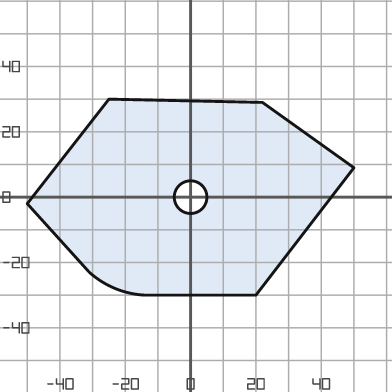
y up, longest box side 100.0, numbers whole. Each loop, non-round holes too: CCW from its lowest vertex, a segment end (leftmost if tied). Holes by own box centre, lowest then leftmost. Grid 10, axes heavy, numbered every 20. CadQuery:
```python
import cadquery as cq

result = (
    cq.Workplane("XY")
    .moveTo(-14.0, -30.0)
    .lineTo(20.0, -30.0)
    .lineTo(50.0, 9.0)
    .lineTo(22.0, 29.0)
    .lineTo(-25.0, 30.0)
    .lineTo(-50.0, -2.0)
    .lineTo(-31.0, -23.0)
    .threePointArc((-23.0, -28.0), (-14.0, -30.0))
    .close()
    .moveTo(0.0, 0.0)
    .circle(5.0)
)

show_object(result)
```